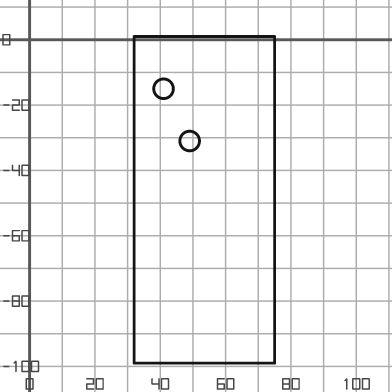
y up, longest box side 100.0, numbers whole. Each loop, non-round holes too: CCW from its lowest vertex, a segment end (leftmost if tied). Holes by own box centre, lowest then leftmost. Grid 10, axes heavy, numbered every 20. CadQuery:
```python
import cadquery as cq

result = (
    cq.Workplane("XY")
    .moveTo(32.0, -99.0)
    .lineTo(75.0, -99.0)
    .lineTo(75.0, 1.0)
    .lineTo(32.0, 1.0)
    .close()
    .moveTo(49.0, -31.0)
    .circle(3.0)
    .moveTo(41.0, -15.0)
    .circle(3.0)
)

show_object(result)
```